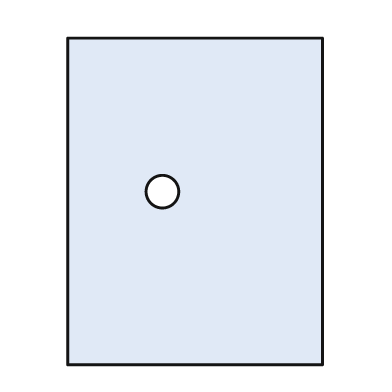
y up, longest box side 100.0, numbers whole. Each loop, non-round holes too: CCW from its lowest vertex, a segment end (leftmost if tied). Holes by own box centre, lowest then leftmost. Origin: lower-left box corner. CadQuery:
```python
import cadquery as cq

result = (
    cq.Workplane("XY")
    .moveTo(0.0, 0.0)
    .lineTo(78.0, 0.0)
    .lineTo(78.0, 100.0)
    .lineTo(0.0, 100.0)
    .close()
    .moveTo(29.0, 53.0)
    .circle(5.0)
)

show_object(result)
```